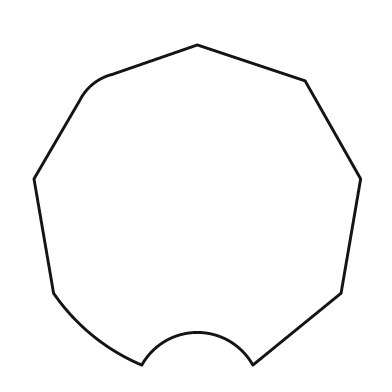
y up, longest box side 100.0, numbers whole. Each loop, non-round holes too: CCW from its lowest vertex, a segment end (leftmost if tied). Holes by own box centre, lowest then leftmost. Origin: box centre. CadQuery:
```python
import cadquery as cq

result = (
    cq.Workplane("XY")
    .moveTo(-17.0, -49.0)
    .threePointArc((0.0, -39.0), (17.0, -49.0))
    .lineTo(44.0, -27.0)
    .lineTo(50.0, 8.0)
    .lineTo(33.0, 38.0)
    .lineTo(0.0, 49.0)
    .lineTo(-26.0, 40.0)
    .threePointArc((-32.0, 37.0), (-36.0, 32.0))
    .lineTo(-50.0, 8.0)
    .lineTo(-44.0, -27.0)
    .threePointArc((-32.0, -40.0), (-17.0, -49.0))
    .close()
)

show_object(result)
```